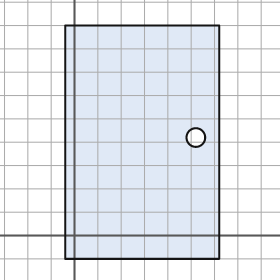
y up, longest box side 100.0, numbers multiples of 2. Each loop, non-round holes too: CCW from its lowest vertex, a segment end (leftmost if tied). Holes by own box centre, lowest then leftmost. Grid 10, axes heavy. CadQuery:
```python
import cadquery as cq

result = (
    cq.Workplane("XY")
    .moveTo(-4.0, -10.0)
    .lineTo(62.0, -10.0)
    .lineTo(62.0, 90.0)
    .lineTo(-4.0, 90.0)
    .close()
    .moveTo(52.0, 42.0)
    .circle(4.0)
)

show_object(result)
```